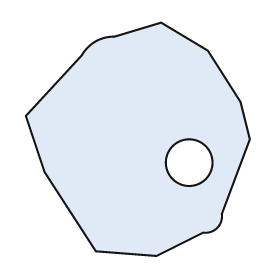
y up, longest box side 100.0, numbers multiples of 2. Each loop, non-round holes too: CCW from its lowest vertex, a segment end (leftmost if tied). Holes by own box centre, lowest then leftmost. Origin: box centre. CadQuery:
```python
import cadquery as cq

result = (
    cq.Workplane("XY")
    .moveTo(8.0, -50.0)
    .lineTo(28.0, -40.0)
    .threePointArc((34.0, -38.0), (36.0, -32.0))
    .lineTo(48.0, 0.0)
    .lineTo(44.0, 16.0)
    .lineTo(30.0, 38.0)
    .lineTo(10.0, 50.0)
    .lineTo(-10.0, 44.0)
    .threePointArc((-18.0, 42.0), (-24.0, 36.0))
    .lineTo(-48.0, 10.0)
    .lineTo(-40.0, -14.0)
    .lineTo(-18.0, -48.0)
    .close()
    .moveTo(22.0, -10.0)
    .circle(10.0)
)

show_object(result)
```